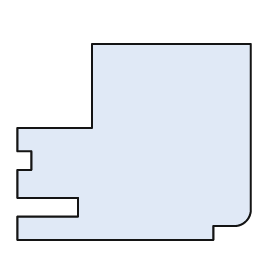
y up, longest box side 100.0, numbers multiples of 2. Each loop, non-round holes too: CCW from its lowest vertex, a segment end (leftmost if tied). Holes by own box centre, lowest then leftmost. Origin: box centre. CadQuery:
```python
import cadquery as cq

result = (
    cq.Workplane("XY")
    .moveTo(-50.0, -42.0)
    .lineTo(34.0, -42.0)
    .lineTo(34.0, -36.0)
    .lineTo(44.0, -36.0)
    .threePointArc((48.0, -34.0), (50.0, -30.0))
    .lineTo(50.0, 42.0)
    .lineTo(-18.0, 42.0)
    .lineTo(-18.0, 6.0)
    .lineTo(-50.0, 6.0)
    .lineTo(-50.0, -4.0)
    .lineTo(-44.0, -4.0)
    .lineTo(-44.0, -12.0)
    .lineTo(-50.0, -12.0)
    .lineTo(-50.0, -24.0)
    .lineTo(-24.0, -24.0)
    .lineTo(-24.0, -32.0)
    .lineTo(-50.0, -32.0)
    .close()
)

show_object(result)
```